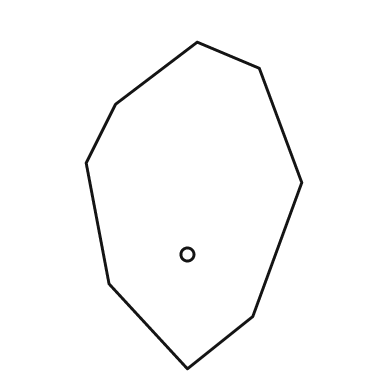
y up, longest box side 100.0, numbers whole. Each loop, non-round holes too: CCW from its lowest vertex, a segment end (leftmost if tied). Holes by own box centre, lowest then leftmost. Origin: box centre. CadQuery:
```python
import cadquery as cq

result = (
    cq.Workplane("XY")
    .moveTo(-2.0, -50.0)
    .lineTo(18.0, -34.0)
    .lineTo(33.0, 7.0)
    .lineTo(20.0, 42.0)
    .lineTo(1.0, 50.0)
    .lineTo(-24.0, 31.0)
    .lineTo(-33.0, 13.0)
    .lineTo(-26.0, -24.0)
    .close()
    .moveTo(-2.0, -15.0)
    .circle(2.0)
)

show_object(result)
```